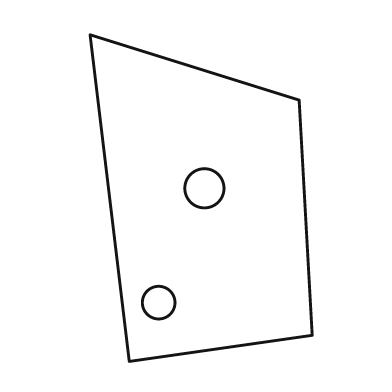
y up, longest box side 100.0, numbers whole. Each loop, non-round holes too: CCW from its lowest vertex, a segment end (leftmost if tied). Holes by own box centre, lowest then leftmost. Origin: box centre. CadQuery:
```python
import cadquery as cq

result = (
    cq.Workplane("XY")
    .moveTo(-22.0, -50.0)
    .lineTo(34.0, -42.0)
    .lineTo(30.0, 30.0)
    .lineTo(-34.0, 50.0)
    .close()
    .moveTo(-13.0, -32.0)
    .circle(5.0)
    .moveTo(1.0, 3.0)
    .circle(6.0)
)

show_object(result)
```